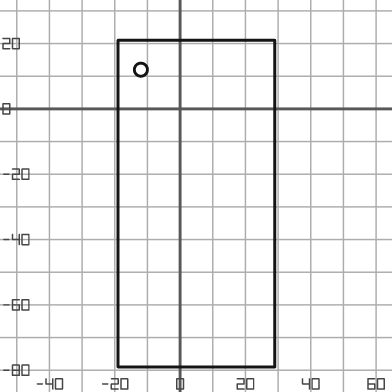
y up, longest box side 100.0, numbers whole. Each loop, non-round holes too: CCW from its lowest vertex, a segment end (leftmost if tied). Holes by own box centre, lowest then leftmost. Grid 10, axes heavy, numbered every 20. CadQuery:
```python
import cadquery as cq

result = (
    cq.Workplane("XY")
    .moveTo(-19.0, -79.0)
    .lineTo(29.0, -79.0)
    .lineTo(29.0, 21.0)
    .lineTo(-19.0, 21.0)
    .close()
    .moveTo(-12.0, 12.0)
    .circle(2.0)
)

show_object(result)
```